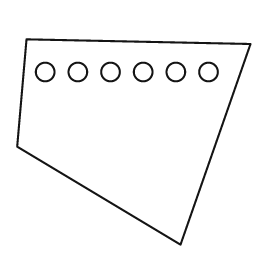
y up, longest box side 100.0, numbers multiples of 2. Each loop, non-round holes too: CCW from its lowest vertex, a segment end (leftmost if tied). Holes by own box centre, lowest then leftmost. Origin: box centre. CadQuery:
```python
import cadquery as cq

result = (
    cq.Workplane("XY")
    .moveTo(20.0, -44.0)
    .lineTo(50.0, 42.0)
    .lineTo(-46.0, 44.0)
    .lineTo(-50.0, -2.0)
    .close()
    .moveTo(-38.0, 30.0)
    .circle(4.0)
    .moveTo(-24.0, 30.0)
    .circle(4.0)
    .moveTo(-10.0, 30.0)
    .circle(4.0)
    .moveTo(4.0, 30.0)
    .circle(4.0)
    .moveTo(18.0, 30.0)
    .circle(4.0)
    .moveTo(32.0, 30.0)
    .circle(4.0)
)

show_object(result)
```